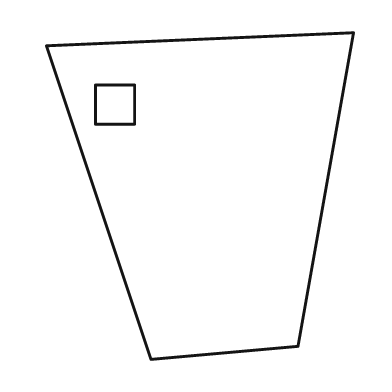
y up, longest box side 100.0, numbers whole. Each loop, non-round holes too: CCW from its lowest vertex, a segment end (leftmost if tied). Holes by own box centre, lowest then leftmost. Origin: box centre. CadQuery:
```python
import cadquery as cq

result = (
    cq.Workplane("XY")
    .moveTo(-15.0, -50.0)
    .lineTo(30.0, -46.0)
    .lineTo(47.0, 50.0)
    .lineTo(-47.0, 46.0)
    .close()
    .moveTo(-32.0, 22.0)
    .lineTo(-20.0, 22.0)
    .lineTo(-20.0, 34.0)
    .lineTo(-32.0, 34.0)
    .close()
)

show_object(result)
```